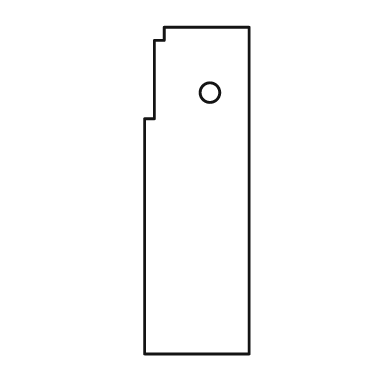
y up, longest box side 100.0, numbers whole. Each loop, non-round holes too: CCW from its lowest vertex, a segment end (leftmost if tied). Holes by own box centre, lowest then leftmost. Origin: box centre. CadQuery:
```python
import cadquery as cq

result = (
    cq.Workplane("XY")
    .moveTo(-16.0, -50.0)
    .lineTo(16.0, -50.0)
    .lineTo(16.0, 50.0)
    .lineTo(-10.0, 50.0)
    .lineTo(-10.0, 46.0)
    .lineTo(-13.0, 46.0)
    .lineTo(-13.0, 22.0)
    .lineTo(-16.0, 22.0)
    .close()
    .moveTo(4.0, 30.0)
    .circle(3.0)
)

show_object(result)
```